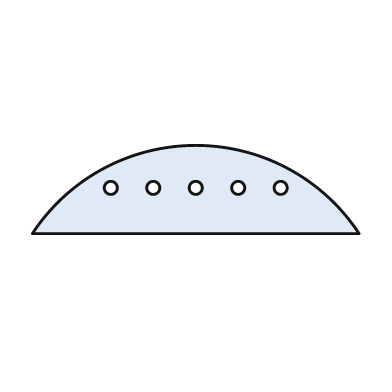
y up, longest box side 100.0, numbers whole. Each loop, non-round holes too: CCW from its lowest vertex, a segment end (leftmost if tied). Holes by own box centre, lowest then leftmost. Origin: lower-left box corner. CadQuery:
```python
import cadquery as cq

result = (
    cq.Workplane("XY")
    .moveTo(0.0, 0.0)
    .lineTo(100.0, 0.0)
    .threePointArc((50.0, 27.0), (0.0, 0.0))
    .close()
    .moveTo(24.0, 14.0)
    .circle(2.0)
    .moveTo(37.0, 14.0)
    .circle(2.0)
    .moveTo(50.0, 14.0)
    .circle(2.0)
    .moveTo(63.0, 14.0)
    .circle(2.0)
    .moveTo(76.0, 14.0)
    .circle(2.0)
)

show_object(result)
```